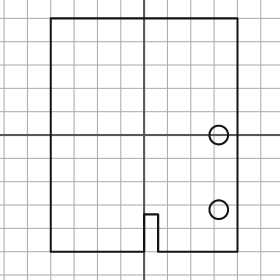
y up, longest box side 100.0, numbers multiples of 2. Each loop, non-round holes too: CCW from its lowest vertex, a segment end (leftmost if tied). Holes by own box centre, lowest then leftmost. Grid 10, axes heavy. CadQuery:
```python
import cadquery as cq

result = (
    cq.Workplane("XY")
    .moveTo(-40.0, -50.0)
    .lineTo(0.0, -50.0)
    .lineTo(0.0, -34.0)
    .lineTo(6.0, -34.0)
    .lineTo(6.0, -50.0)
    .lineTo(40.0, -50.0)
    .lineTo(40.0, 50.0)
    .lineTo(-40.0, 50.0)
    .close()
    .moveTo(32.0, -32.0)
    .circle(4.0)
    .moveTo(32.0, 0.0)
    .circle(4.0)
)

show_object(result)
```